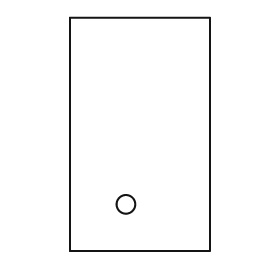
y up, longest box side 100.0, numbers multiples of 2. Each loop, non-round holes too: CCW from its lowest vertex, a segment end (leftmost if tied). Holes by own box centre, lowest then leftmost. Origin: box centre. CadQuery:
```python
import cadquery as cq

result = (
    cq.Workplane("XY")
    .moveTo(-30.0, -50.0)
    .lineTo(30.0, -50.0)
    .lineTo(30.0, 50.0)
    .lineTo(-30.0, 50.0)
    .close()
    .moveTo(-6.0, -30.0)
    .circle(4.0)
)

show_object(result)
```